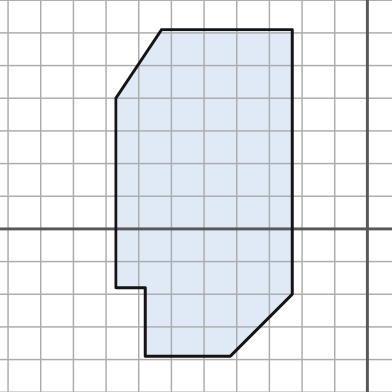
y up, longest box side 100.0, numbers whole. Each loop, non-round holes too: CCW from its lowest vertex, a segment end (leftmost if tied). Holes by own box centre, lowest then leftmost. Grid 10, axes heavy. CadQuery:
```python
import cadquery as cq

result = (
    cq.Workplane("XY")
    .moveTo(-68.0, -39.0)
    .lineTo(-42.0, -39.0)
    .lineTo(-23.0, -20.0)
    .lineTo(-23.0, 61.0)
    .lineTo(-63.0, 61.0)
    .lineTo(-77.0, 40.0)
    .lineTo(-77.0, -18.0)
    .lineTo(-68.0, -18.0)
    .close()
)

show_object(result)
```